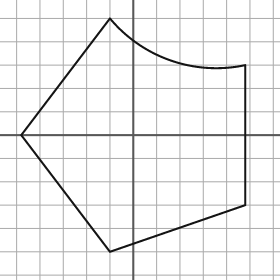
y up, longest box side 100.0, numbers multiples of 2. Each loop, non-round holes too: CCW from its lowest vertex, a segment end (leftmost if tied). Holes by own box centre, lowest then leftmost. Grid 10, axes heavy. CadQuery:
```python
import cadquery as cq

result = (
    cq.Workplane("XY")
    .moveTo(-10.0, -50.0)
    .lineTo(48.0, -30.0)
    .lineTo(48.0, 30.0)
    .threePointArc((16.0, 32.0), (-10.0, 50.0))
    .lineTo(-48.0, 0.0)
    .close()
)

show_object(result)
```